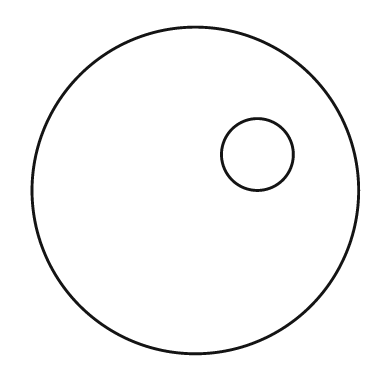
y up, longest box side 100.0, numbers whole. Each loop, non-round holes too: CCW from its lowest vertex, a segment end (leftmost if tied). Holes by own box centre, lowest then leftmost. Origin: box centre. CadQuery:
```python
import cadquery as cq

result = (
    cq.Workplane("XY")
    .moveTo(0.0, 0.0)
    .circle(50.0)
    .moveTo(19.0, 11.0)
    .circle(11.0)
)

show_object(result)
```